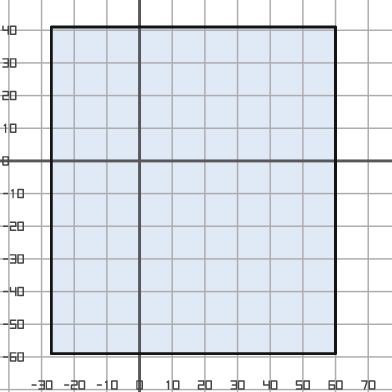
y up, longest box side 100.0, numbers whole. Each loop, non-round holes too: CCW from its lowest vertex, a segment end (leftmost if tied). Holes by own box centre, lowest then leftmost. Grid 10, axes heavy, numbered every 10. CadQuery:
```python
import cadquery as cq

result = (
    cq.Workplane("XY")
    .moveTo(-27.0, -59.0)
    .lineTo(60.0, -59.0)
    .lineTo(60.0, 41.0)
    .lineTo(-27.0, 41.0)
    .close()
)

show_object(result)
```